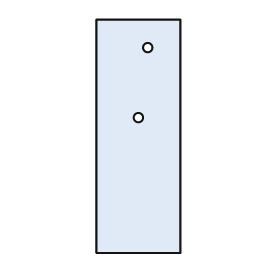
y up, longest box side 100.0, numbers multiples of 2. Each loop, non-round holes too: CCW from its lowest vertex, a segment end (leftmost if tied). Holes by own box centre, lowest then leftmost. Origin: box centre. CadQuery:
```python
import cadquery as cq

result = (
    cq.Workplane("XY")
    .moveTo(-18.0, -50.0)
    .lineTo(18.0, -50.0)
    .lineTo(18.0, 50.0)
    .lineTo(-18.0, 50.0)
    .close()
    .moveTo(0.0, 8.0)
    .circle(2.0)
    .moveTo(4.0, 38.0)
    .circle(2.0)
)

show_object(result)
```